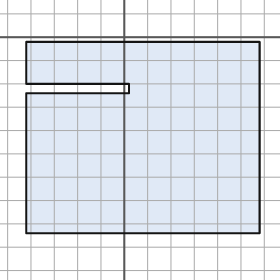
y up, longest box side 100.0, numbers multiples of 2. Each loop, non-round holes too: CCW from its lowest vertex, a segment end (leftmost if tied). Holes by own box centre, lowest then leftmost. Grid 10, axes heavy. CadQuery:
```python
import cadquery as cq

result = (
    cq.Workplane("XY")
    .moveTo(-42.0, -84.0)
    .lineTo(58.0, -84.0)
    .lineTo(58.0, -2.0)
    .lineTo(-42.0, -2.0)
    .lineTo(-42.0, -20.0)
    .lineTo(2.0, -20.0)
    .lineTo(2.0, -24.0)
    .lineTo(-42.0, -24.0)
    .close()
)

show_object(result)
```